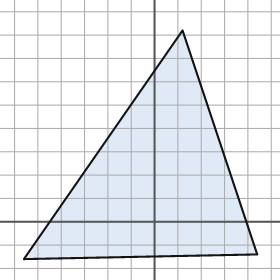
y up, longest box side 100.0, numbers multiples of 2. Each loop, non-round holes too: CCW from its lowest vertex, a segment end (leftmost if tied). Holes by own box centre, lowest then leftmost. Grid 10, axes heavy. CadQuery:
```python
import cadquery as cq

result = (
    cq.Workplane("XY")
    .moveTo(-56.0, -16.0)
    .lineTo(44.0, -14.0)
    .lineTo(12.0, 82.0)
    .close()
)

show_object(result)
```